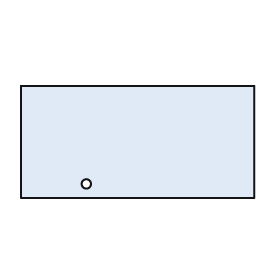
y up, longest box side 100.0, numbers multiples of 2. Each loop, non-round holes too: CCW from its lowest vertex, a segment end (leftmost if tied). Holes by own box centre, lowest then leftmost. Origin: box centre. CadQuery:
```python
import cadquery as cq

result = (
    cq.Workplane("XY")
    .moveTo(-50.0, -24.0)
    .lineTo(50.0, -24.0)
    .lineTo(50.0, 24.0)
    .lineTo(-50.0, 24.0)
    .close()
    .moveTo(-22.0, -18.0)
    .circle(2.0)
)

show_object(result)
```